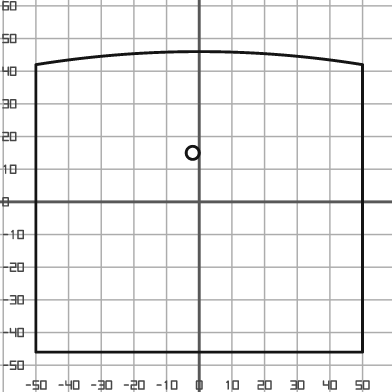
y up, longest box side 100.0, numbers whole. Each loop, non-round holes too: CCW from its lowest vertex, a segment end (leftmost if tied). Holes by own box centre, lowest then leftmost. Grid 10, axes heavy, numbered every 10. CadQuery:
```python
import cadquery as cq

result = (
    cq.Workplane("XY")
    .moveTo(-50.0, -46.0)
    .lineTo(50.0, -46.0)
    .lineTo(50.0, 42.0)
    .threePointArc((0.0, 46.0), (-50.0, 42.0))
    .close()
    .moveTo(-2.0, 15.0)
    .circle(2.0)
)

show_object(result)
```